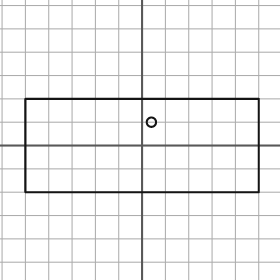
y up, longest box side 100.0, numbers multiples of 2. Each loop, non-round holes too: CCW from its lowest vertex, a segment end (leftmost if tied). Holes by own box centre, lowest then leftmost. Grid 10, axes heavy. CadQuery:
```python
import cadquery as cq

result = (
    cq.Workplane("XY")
    .moveTo(-50.0, -20.0)
    .lineTo(50.0, -20.0)
    .lineTo(50.0, 20.0)
    .lineTo(-50.0, 20.0)
    .close()
    .moveTo(4.0, 10.0)
    .circle(2.0)
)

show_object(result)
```